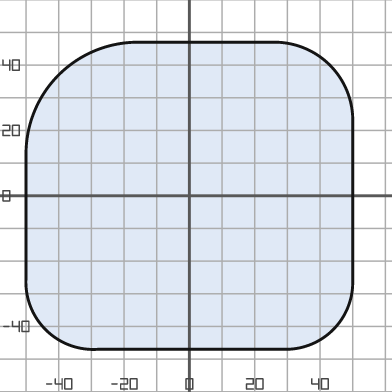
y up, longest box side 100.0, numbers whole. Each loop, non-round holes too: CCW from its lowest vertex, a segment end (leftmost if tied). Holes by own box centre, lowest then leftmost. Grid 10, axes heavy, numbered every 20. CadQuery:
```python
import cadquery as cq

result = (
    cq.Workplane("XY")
    .moveTo(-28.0, -47.0)
    .lineTo(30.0, -47.0)
    .threePointArc((44.0, -41.0), (50.0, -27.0))
    .lineTo(50.0, 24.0)
    .threePointArc((43.0, 40.0), (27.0, 47.0))
    .lineTo(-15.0, 47.0)
    .threePointArc((-40.0, 37.0), (-50.0, 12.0))
    .lineTo(-50.0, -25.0)
    .threePointArc((-44.0, -41.0), (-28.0, -47.0))
    .close()
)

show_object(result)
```